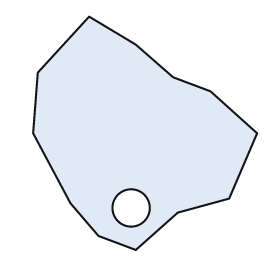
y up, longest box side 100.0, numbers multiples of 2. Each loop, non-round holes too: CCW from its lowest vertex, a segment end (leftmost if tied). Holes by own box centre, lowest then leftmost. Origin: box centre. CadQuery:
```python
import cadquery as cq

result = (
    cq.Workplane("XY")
    .moveTo(-4.0, -50.0)
    .lineTo(14.0, -34.0)
    .lineTo(36.0, -28.0)
    .lineTo(48.0, 0.0)
    .lineTo(28.0, 18.0)
    .lineTo(12.0, 24.0)
    .lineTo(-4.0, 38.0)
    .lineTo(-24.0, 50.0)
    .lineTo(-46.0, 26.0)
    .lineTo(-48.0, 0.0)
    .lineTo(-32.0, -30.0)
    .lineTo(-20.0, -44.0)
    .close()
    .moveTo(-6.0, -32.0)
    .circle(8.0)
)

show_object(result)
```